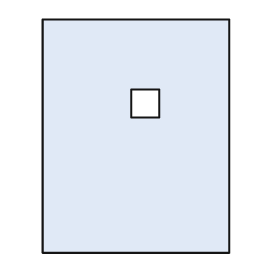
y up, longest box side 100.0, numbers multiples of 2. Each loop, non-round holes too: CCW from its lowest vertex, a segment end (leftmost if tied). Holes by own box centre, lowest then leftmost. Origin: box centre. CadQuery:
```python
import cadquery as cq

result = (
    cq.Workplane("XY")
    .moveTo(-40.0, -50.0)
    .lineTo(40.0, -50.0)
    .lineTo(40.0, 50.0)
    .lineTo(-40.0, 50.0)
    .close()
    .moveTo(-2.0, 8.0)
    .lineTo(10.0, 8.0)
    .lineTo(10.0, 20.0)
    .lineTo(-2.0, 20.0)
    .close()
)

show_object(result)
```